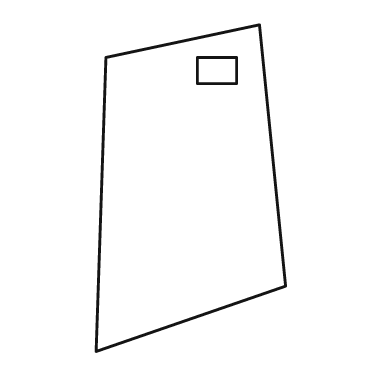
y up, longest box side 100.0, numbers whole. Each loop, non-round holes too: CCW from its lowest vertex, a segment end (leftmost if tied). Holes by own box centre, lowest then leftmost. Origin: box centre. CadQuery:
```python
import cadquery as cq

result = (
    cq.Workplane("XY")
    .moveTo(-29.0, -50.0)
    .lineTo(29.0, -30.0)
    .lineTo(21.0, 50.0)
    .lineTo(-26.0, 40.0)
    .close()
    .moveTo(2.0, 32.0)
    .lineTo(14.0, 32.0)
    .lineTo(14.0, 40.0)
    .lineTo(2.0, 40.0)
    .close()
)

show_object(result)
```